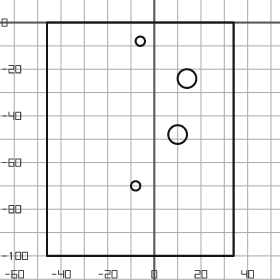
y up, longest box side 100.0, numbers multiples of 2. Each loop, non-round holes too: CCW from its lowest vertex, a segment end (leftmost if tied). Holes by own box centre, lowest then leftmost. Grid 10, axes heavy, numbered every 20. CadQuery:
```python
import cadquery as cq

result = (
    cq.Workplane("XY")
    .moveTo(-46.0, -100.0)
    .lineTo(34.0, -100.0)
    .lineTo(34.0, 0.0)
    .lineTo(-46.0, 0.0)
    .close()
    .moveTo(-8.0, -70.0)
    .circle(2.0)
    .moveTo(10.0, -48.0)
    .circle(4.0)
    .moveTo(14.0, -24.0)
    .circle(4.0)
    .moveTo(-6.0, -8.0)
    .circle(2.0)
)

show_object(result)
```